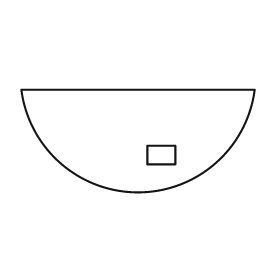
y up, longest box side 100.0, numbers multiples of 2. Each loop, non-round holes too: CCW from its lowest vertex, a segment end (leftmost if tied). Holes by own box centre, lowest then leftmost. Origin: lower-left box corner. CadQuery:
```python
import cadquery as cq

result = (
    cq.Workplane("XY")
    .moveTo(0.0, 44.0)
    .threePointArc((50.0, 0.0), (100.0, 44.0))
    .close()
    .moveTo(54.0, 12.0)
    .lineTo(66.0, 12.0)
    .lineTo(66.0, 20.0)
    .lineTo(54.0, 20.0)
    .close()
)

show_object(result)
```